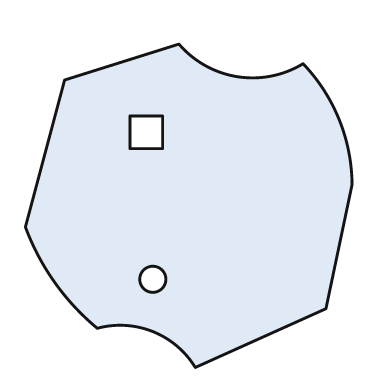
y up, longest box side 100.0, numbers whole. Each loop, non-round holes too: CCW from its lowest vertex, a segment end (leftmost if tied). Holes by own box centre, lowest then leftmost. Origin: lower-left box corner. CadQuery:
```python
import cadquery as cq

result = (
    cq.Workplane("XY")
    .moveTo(52.0, 0.0)
    .lineTo(92.0, 18.0)
    .lineTo(100.0, 56.0)
    .threePointArc((96.0, 76.0), (85.0, 93.0))
    .threePointArc((65.0, 89.0), (47.0, 99.0))
    .lineTo(12.0, 88.0)
    .lineTo(0.0, 43.0)
    .threePointArc((9.0, 26.0), (22.0, 12.0))
    .threePointArc((39.0, 11.0), (52.0, 0.0))
    .close()
    .moveTo(39.0, 27.0)
    .circle(4.0)
    .moveTo(32.0, 67.0)
    .lineTo(42.0, 67.0)
    .lineTo(42.0, 77.0)
    .lineTo(32.0, 77.0)
    .close()
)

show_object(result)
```